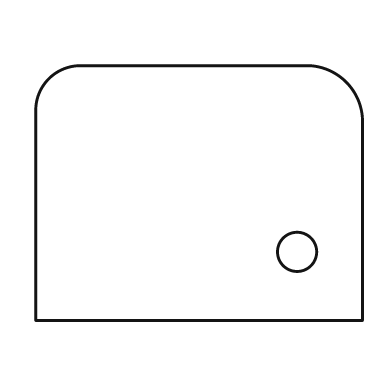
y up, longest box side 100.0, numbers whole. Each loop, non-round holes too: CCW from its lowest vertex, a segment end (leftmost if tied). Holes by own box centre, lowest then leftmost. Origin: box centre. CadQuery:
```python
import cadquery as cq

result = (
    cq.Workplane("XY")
    .moveTo(-50.0, -39.0)
    .lineTo(50.0, -39.0)
    .lineTo(50.0, 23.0)
    .threePointArc((45.0, 34.0), (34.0, 39.0))
    .lineTo(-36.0, 39.0)
    .threePointArc((-46.0, 35.0), (-50.0, 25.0))
    .close()
    .moveTo(30.0, -18.0)
    .circle(6.0)
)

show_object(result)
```